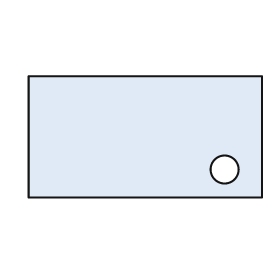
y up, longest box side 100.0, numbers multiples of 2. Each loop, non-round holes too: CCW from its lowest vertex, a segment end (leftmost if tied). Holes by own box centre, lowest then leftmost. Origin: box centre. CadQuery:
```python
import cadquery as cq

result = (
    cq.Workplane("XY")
    .moveTo(-50.0, -26.0)
    .lineTo(50.0, -26.0)
    .lineTo(50.0, 26.0)
    .lineTo(-50.0, 26.0)
    .close()
    .moveTo(34.0, -14.0)
    .circle(6.0)
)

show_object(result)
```